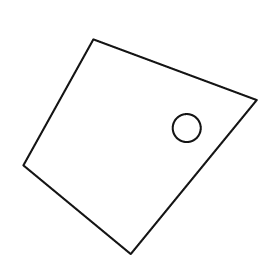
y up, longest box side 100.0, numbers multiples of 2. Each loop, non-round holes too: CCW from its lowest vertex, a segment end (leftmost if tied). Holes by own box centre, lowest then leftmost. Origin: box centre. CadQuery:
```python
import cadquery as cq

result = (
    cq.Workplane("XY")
    .moveTo(-4.0, -46.0)
    .lineTo(50.0, 20.0)
    .lineTo(-20.0, 46.0)
    .lineTo(-50.0, -8.0)
    .close()
    .moveTo(20.0, 8.0)
    .circle(6.0)
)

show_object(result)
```